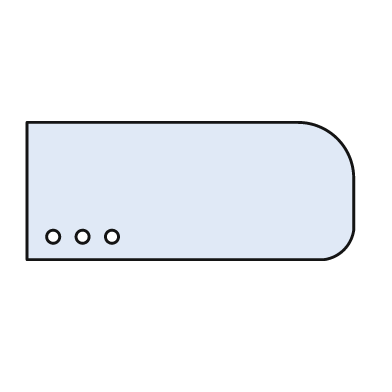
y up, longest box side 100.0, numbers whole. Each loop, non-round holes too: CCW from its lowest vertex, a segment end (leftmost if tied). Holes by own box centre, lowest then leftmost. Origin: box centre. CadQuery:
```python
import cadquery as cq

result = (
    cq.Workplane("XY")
    .moveTo(-50.0, -21.0)
    .lineTo(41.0, -21.0)
    .threePointArc((47.0, -18.0), (50.0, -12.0))
    .lineTo(50.0, 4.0)
    .threePointArc((45.0, 16.0), (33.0, 21.0))
    .lineTo(-50.0, 21.0)
    .close()
    .moveTo(-42.0, -14.0)
    .circle(2.0)
    .moveTo(-33.0, -14.0)
    .circle(2.0)
    .moveTo(-24.0, -14.0)
    .circle(2.0)
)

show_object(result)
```